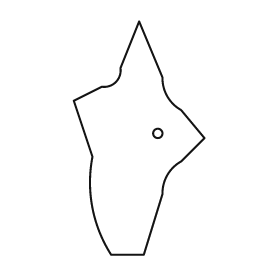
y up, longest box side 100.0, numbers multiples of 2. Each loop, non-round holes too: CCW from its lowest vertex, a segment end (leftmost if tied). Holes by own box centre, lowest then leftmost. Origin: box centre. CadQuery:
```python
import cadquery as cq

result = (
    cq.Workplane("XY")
    .moveTo(-12.0, -50.0)
    .lineTo(2.0, -50.0)
    .lineTo(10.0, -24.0)
    .threePointArc((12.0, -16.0), (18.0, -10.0))
    .lineTo(28.0, 0.0)
    .lineTo(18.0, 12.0)
    .threePointArc((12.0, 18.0), (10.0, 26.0))
    .lineTo(0.0, 50.0)
    .lineTo(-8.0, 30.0)
    .threePointArc((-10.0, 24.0), (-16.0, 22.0))
    .lineTo(-28.0, 16.0)
    .lineTo(-20.0, -8.0)
    .threePointArc((-20.0, -30.0), (-12.0, -50.0))
    .close()
    .moveTo(8.0, 2.0)
    .circle(2.0)
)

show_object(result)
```